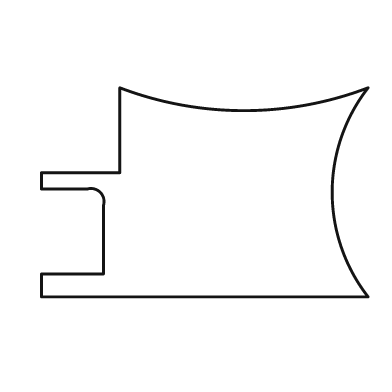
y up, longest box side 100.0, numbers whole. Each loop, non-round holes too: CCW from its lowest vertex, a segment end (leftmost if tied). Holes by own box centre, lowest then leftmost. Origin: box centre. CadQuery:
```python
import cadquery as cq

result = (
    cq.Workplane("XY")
    .moveTo(-50.0, -32.0)
    .lineTo(50.0, -32.0)
    .threePointArc((39.0, 0.0), (50.0, 32.0))
    .threePointArc((12.0, 25.0), (-26.0, 32.0))
    .lineTo(-26.0, 6.0)
    .lineTo(-50.0, 6.0)
    .lineTo(-50.0, 1.0)
    .lineTo(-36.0, 1.0)
    .threePointArc((-32.0, 0.0), (-31.0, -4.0))
    .lineTo(-31.0, -25.0)
    .lineTo(-50.0, -25.0)
    .close()
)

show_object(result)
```